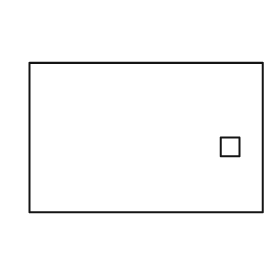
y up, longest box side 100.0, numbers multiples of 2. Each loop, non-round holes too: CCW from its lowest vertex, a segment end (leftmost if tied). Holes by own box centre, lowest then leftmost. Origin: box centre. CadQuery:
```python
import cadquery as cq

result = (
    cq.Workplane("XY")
    .moveTo(-50.0, -32.0)
    .lineTo(50.0, -32.0)
    .lineTo(50.0, 32.0)
    .lineTo(-50.0, 32.0)
    .close()
    .moveTo(32.0, -8.0)
    .lineTo(40.0, -8.0)
    .lineTo(40.0, 0.0)
    .lineTo(32.0, 0.0)
    .close()
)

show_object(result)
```